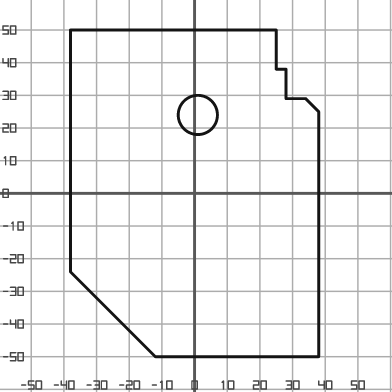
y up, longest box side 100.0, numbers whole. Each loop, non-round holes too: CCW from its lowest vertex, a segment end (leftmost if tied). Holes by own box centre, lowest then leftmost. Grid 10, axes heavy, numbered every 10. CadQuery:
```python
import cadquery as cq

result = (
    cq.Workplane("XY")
    .moveTo(-12.0, -50.0)
    .lineTo(38.0, -50.0)
    .lineTo(38.0, 25.0)
    .lineTo(34.0, 29.0)
    .lineTo(28.0, 29.0)
    .lineTo(28.0, 38.0)
    .lineTo(25.0, 38.0)
    .lineTo(25.0, 50.0)
    .lineTo(-38.0, 50.0)
    .lineTo(-38.0, -24.0)
    .close()
    .moveTo(1.0, 24.0)
    .circle(6.0)
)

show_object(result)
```